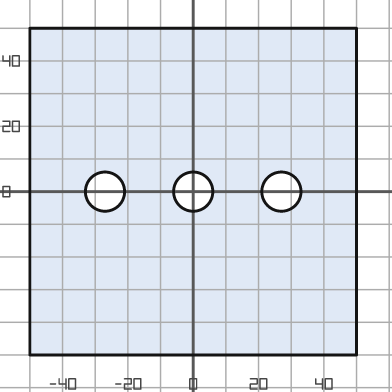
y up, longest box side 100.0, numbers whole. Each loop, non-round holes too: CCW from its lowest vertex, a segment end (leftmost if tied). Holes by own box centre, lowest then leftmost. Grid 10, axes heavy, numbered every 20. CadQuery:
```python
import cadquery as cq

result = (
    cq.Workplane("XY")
    .moveTo(-50.0, -50.0)
    .lineTo(50.0, -50.0)
    .lineTo(50.0, 50.0)
    .lineTo(-50.0, 50.0)
    .close()
    .moveTo(-27.0, 0.0)
    .circle(6.0)
    .moveTo(0.0, 0.0)
    .circle(6.0)
    .moveTo(27.0, 0.0)
    .circle(6.0)
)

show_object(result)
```